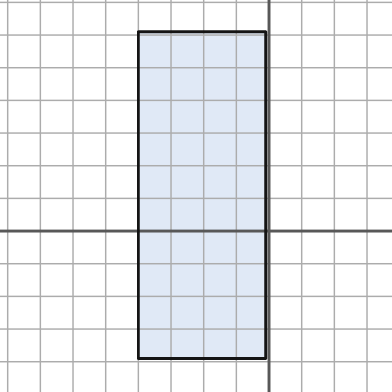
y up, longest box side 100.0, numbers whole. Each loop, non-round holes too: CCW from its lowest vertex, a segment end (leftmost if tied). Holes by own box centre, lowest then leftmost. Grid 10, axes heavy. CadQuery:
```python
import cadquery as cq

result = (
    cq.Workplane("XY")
    .moveTo(-40.0, -39.0)
    .lineTo(-1.0, -39.0)
    .lineTo(-1.0, 61.0)
    .lineTo(-40.0, 61.0)
    .close()
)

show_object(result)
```